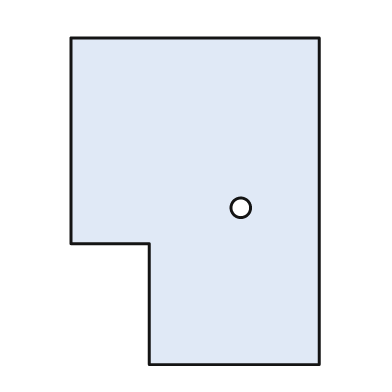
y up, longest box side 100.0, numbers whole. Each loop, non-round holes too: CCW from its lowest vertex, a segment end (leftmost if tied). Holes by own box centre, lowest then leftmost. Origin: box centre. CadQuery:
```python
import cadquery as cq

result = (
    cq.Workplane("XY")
    .moveTo(-14.0, -50.0)
    .lineTo(38.0, -50.0)
    .lineTo(38.0, 50.0)
    .lineTo(-38.0, 50.0)
    .lineTo(-38.0, -13.0)
    .lineTo(-14.0, -13.0)
    .close()
    .moveTo(14.0, -2.0)
    .circle(3.0)
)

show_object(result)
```